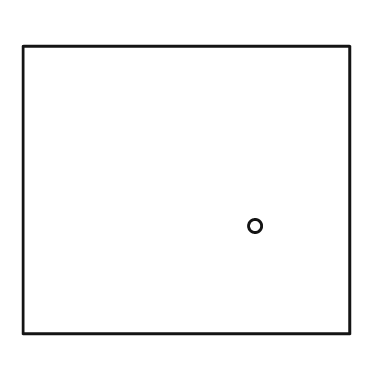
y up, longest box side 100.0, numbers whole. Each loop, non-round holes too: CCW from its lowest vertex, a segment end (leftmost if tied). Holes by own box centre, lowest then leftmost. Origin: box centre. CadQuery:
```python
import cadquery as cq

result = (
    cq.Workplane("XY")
    .moveTo(-50.0, -44.0)
    .lineTo(50.0, -44.0)
    .lineTo(50.0, 44.0)
    .lineTo(-50.0, 44.0)
    .close()
    .moveTo(21.0, -11.0)
    .circle(2.0)
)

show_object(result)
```